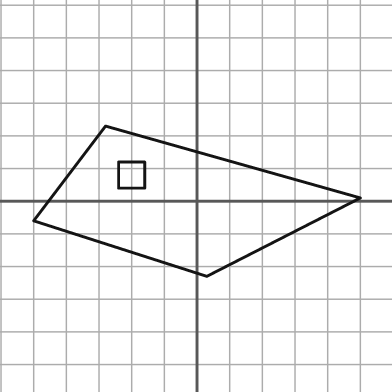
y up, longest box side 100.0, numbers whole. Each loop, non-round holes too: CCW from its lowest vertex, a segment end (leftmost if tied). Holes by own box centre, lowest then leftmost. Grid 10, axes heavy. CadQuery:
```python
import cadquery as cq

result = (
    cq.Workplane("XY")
    .moveTo(3.0, -23.0)
    .lineTo(50.0, 1.0)
    .lineTo(-28.0, 23.0)
    .lineTo(-50.0, -6.0)
    .close()
    .moveTo(-24.0, 4.0)
    .lineTo(-16.0, 4.0)
    .lineTo(-16.0, 12.0)
    .lineTo(-24.0, 12.0)
    .close()
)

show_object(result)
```